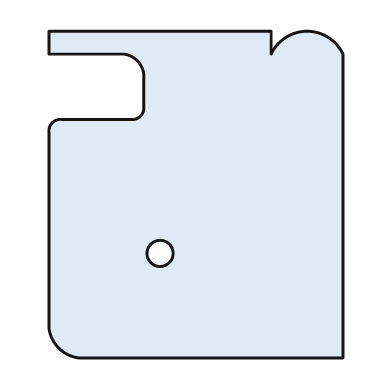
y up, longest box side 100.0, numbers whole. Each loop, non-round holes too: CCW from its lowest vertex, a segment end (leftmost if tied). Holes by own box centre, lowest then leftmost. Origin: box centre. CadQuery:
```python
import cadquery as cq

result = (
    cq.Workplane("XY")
    .moveTo(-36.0, -50.0)
    .lineTo(45.0, -50.0)
    .lineTo(45.0, 43.0)
    .threePointArc((34.0, 50.0), (23.0, 43.0))
    .lineTo(23.0, 50.0)
    .lineTo(-45.0, 50.0)
    .lineTo(-45.0, 43.0)
    .lineTo(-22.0, 43.0)
    .threePointArc((-18.0, 41.0), (-16.0, 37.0))
    .lineTo(-16.0, 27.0)
    .threePointArc((-17.0, 24.0), (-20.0, 23.0))
    .lineTo(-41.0, 23.0)
    .threePointArc((-44.0, 22.0), (-45.0, 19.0))
    .lineTo(-45.0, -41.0)
    .threePointArc((-42.0, -47.0), (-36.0, -50.0))
    .close()
    .moveTo(-11.0, -18.0)
    .circle(4.0)
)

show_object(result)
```